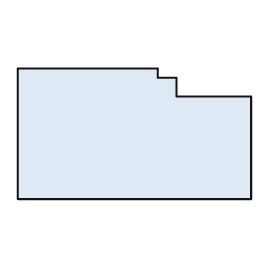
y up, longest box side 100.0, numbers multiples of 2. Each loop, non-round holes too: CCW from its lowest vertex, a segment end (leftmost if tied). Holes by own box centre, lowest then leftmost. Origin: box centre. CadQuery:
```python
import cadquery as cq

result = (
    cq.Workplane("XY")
    .moveTo(-50.0, -28.0)
    .lineTo(50.0, -28.0)
    .lineTo(50.0, 16.0)
    .lineTo(18.0, 16.0)
    .lineTo(18.0, 24.0)
    .lineTo(10.0, 24.0)
    .lineTo(10.0, 28.0)
    .lineTo(-50.0, 28.0)
    .close()
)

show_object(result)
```